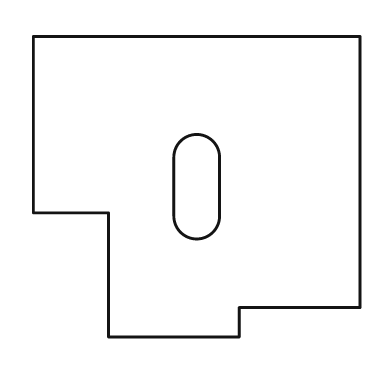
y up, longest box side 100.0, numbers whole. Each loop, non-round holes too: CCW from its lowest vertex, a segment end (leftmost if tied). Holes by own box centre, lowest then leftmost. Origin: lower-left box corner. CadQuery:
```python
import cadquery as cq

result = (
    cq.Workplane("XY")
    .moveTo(23.0, 0.0)
    .lineTo(63.0, 0.0)
    .lineTo(63.0, 9.0)
    .lineTo(100.0, 9.0)
    .lineTo(100.0, 92.0)
    .lineTo(0.0, 92.0)
    .lineTo(0.0, 38.0)
    .lineTo(23.0, 38.0)
    .close()
    .moveTo(43.0, 37.0)
    .threePointArc((50.0, 30.0), (57.0, 37.0))
    .lineTo(57.0, 55.0)
    .threePointArc((50.0, 62.0), (43.0, 55.0))
    .close()
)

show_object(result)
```